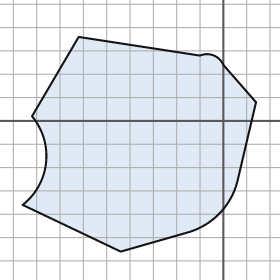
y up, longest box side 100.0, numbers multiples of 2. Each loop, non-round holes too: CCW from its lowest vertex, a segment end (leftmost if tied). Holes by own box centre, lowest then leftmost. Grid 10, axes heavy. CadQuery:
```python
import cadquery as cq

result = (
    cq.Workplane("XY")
    .moveTo(-44.0, -56.0)
    .lineTo(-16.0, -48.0)
    .threePointArc((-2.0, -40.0), (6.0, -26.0))
    .lineTo(14.0, 8.0)
    .lineTo(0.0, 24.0)
    .threePointArc((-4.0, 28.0), (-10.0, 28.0))
    .lineTo(-62.0, 36.0)
    .lineTo(-82.0, 2.0)
    .threePointArc((-76.0, -18.0), (-86.0, -36.0))
    .close()
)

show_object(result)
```